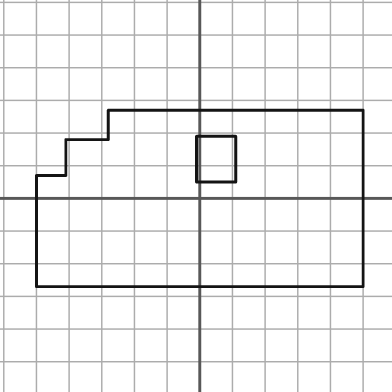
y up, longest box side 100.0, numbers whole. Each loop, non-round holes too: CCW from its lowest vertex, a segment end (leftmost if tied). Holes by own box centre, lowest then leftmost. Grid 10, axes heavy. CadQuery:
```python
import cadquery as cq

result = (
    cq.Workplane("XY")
    .moveTo(-50.0, -27.0)
    .lineTo(50.0, -27.0)
    .lineTo(50.0, 27.0)
    .lineTo(-28.0, 27.0)
    .lineTo(-28.0, 18.0)
    .lineTo(-41.0, 18.0)
    .lineTo(-41.0, 7.0)
    .lineTo(-50.0, 7.0)
    .close()
    .moveTo(-1.0, 5.0)
    .lineTo(11.0, 5.0)
    .lineTo(11.0, 19.0)
    .lineTo(-1.0, 19.0)
    .close()
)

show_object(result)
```